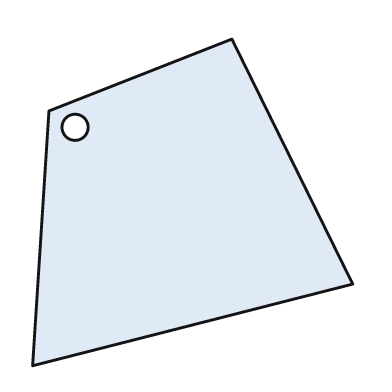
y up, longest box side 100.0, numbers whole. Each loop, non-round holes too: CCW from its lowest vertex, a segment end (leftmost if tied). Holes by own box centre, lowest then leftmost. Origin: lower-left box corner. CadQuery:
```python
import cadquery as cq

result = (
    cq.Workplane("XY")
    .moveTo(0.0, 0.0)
    .lineTo(98.0, 25.0)
    .lineTo(61.0, 100.0)
    .lineTo(5.0, 78.0)
    .close()
    .moveTo(13.0, 73.0)
    .circle(4.0)
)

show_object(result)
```